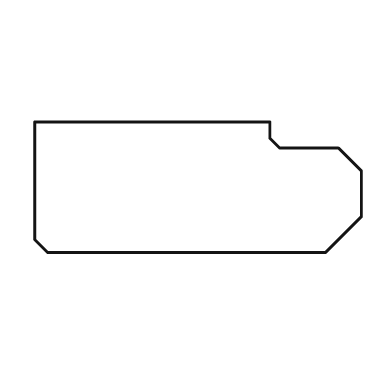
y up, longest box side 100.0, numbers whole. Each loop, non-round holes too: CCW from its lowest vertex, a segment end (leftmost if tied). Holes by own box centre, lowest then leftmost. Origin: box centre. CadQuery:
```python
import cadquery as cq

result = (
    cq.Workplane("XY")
    .moveTo(-46.0, -20.0)
    .lineTo(39.0, -20.0)
    .lineTo(50.0, -9.0)
    .lineTo(50.0, 5.0)
    .lineTo(43.0, 12.0)
    .lineTo(25.0, 12.0)
    .lineTo(22.0, 15.0)
    .lineTo(22.0, 20.0)
    .lineTo(-50.0, 20.0)
    .lineTo(-50.0, -16.0)
    .close()
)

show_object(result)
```